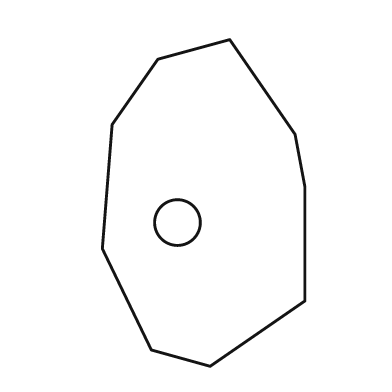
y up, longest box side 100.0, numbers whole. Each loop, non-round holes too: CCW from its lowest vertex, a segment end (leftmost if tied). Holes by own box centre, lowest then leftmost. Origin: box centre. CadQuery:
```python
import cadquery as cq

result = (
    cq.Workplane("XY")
    .moveTo(2.0, -50.0)
    .lineTo(31.0, -30.0)
    .lineTo(31.0, 5.0)
    .lineTo(28.0, 21.0)
    .lineTo(8.0, 50.0)
    .lineTo(-14.0, 44.0)
    .lineTo(-28.0, 24.0)
    .lineTo(-31.0, -14.0)
    .lineTo(-16.0, -45.0)
    .close()
    .moveTo(-8.0, -6.0)
    .circle(7.0)
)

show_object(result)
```